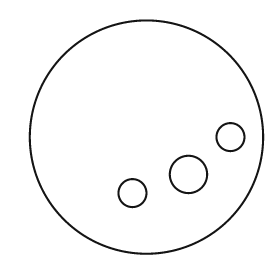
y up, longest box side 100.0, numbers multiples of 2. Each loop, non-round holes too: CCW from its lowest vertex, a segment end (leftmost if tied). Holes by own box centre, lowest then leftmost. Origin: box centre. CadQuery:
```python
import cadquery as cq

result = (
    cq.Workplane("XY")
    .moveTo(0.0, 0.0)
    .circle(50.0)
    .moveTo(-6.0, -24.0)
    .circle(6.0)
    .moveTo(18.0, -16.0)
    .circle(8.0)
    .moveTo(36.0, 0.0)
    .circle(6.0)
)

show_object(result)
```